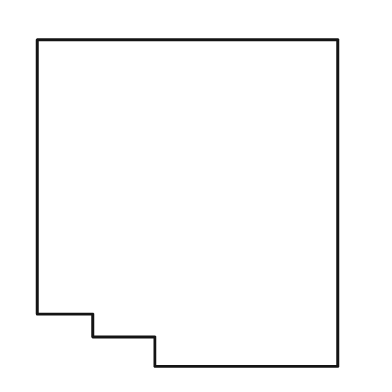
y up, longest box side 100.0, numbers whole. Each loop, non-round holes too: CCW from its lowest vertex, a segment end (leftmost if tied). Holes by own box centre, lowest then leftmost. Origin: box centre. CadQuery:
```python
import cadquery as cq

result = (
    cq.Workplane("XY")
    .moveTo(-10.0, -50.0)
    .lineTo(46.0, -50.0)
    .lineTo(46.0, 50.0)
    .lineTo(-46.0, 50.0)
    .lineTo(-46.0, -34.0)
    .lineTo(-29.0, -34.0)
    .lineTo(-29.0, -41.0)
    .lineTo(-10.0, -41.0)
    .close()
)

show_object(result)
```